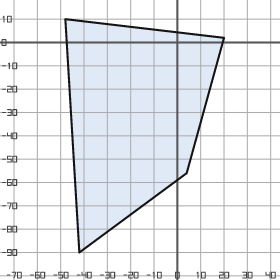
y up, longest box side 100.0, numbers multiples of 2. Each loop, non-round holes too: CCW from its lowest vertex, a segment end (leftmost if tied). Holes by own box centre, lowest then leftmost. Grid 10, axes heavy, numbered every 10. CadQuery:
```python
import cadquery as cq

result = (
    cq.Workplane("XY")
    .moveTo(-42.0, -90.0)
    .lineTo(4.0, -56.0)
    .lineTo(20.0, 2.0)
    .lineTo(-48.0, 10.0)
    .close()
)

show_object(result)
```